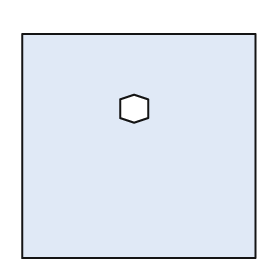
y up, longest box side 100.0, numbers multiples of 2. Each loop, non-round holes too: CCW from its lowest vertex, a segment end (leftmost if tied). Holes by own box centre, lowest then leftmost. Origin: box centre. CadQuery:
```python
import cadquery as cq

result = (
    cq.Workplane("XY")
    .moveTo(-50.0, -48.0)
    .lineTo(50.0, -48.0)
    .lineTo(50.0, 48.0)
    .lineTo(-50.0, 48.0)
    .close()
    .moveTo(-2.0, 10.0)
    .lineTo(4.0, 12.0)
    .lineTo(4.0, 20.0)
    .lineTo(-2.0, 22.0)
    .lineTo(-8.0, 20.0)
    .lineTo(-8.0, 12.0)
    .close()
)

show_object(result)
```